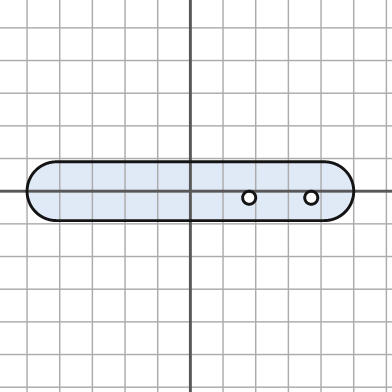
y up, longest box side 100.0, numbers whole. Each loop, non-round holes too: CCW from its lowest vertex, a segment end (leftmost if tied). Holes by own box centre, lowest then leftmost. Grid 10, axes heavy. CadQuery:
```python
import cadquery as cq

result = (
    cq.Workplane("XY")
    .moveTo(-41.0, -9.0)
    .lineTo(41.0, -9.0)
    .threePointArc((50.0, 0.0), (41.0, 9.0))
    .lineTo(-41.0, 9.0)
    .threePointArc((-50.0, 0.0), (-41.0, -9.0))
    .close()
    .moveTo(18.0, -2.0)
    .circle(2.0)
    .moveTo(37.0, -2.0)
    .circle(2.0)
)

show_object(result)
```